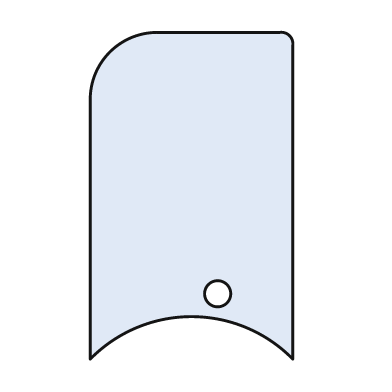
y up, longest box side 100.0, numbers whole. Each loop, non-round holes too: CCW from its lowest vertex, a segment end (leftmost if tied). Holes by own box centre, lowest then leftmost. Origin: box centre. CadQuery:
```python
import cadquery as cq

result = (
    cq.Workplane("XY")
    .moveTo(-31.0, -50.0)
    .threePointArc((0.0, -37.0), (31.0, -50.0))
    .lineTo(31.0, 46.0)
    .threePointArc((30.0, 49.0), (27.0, 50.0))
    .lineTo(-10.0, 50.0)
    .threePointArc((-25.0, 44.0), (-31.0, 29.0))
    .close()
    .moveTo(8.0, -30.0)
    .circle(4.0)
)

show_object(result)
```